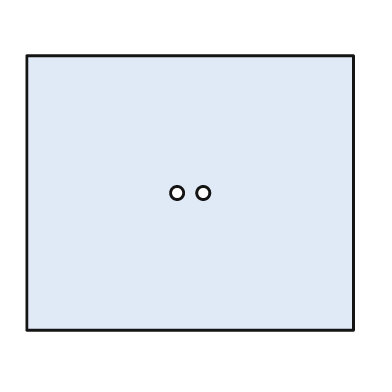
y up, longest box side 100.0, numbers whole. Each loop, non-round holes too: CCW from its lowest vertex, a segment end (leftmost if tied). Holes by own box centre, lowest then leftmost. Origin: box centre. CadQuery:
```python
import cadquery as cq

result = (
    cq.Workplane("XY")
    .moveTo(-50.0, -42.0)
    .lineTo(50.0, -42.0)
    .lineTo(50.0, 42.0)
    .lineTo(-50.0, 42.0)
    .close()
    .moveTo(-4.0, 0.0)
    .circle(2.0)
    .moveTo(4.0, 0.0)
    .circle(2.0)
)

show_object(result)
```